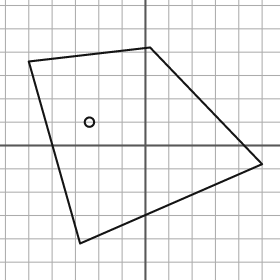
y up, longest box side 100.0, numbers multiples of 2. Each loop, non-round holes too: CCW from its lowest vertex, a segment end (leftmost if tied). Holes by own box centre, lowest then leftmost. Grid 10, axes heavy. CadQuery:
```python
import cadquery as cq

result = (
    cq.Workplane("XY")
    .moveTo(-28.0, -42.0)
    .lineTo(50.0, -8.0)
    .lineTo(2.0, 42.0)
    .lineTo(-50.0, 36.0)
    .close()
    .moveTo(-24.0, 10.0)
    .circle(2.0)
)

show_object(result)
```